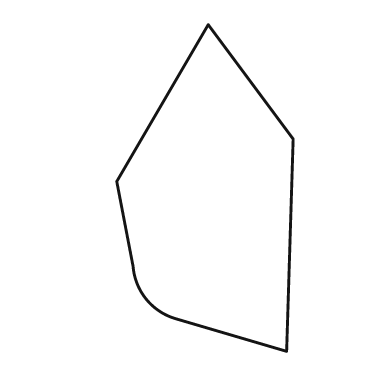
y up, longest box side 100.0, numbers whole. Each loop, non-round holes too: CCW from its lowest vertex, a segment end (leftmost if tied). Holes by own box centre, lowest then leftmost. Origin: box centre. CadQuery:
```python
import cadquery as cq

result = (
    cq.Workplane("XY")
    .moveTo(25.0, -50.0)
    .lineTo(27.0, 15.0)
    .lineTo(1.0, 50.0)
    .lineTo(-27.0, 2.0)
    .lineTo(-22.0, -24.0)
    .threePointArc((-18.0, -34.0), (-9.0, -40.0))
    .close()
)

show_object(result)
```